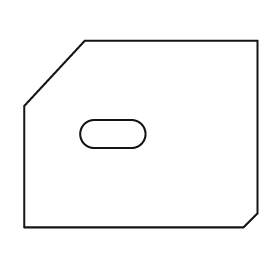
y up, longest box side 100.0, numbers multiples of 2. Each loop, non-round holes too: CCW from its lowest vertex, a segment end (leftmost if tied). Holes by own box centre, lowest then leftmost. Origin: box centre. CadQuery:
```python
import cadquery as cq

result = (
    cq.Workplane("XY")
    .moveTo(-50.0, -40.0)
    .lineTo(44.0, -40.0)
    .lineTo(50.0, -34.0)
    .lineTo(50.0, 40.0)
    .lineTo(-24.0, 40.0)
    .lineTo(-50.0, 12.0)
    .close()
    .moveTo(-20.0, -6.0)
    .lineTo(-4.0, -6.0)
    .threePointArc((2.0, 0.0), (-4.0, 6.0))
    .lineTo(-20.0, 6.0)
    .threePointArc((-26.0, 0.0), (-20.0, -6.0))
    .close()
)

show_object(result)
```